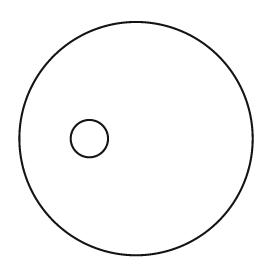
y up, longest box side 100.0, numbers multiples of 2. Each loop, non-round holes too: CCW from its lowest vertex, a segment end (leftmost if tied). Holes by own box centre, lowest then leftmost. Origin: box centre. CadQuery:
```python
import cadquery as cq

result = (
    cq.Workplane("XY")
    .moveTo(0.0, 0.0)
    .circle(50.0)
    .moveTo(-20.0, 0.0)
    .circle(8.0)
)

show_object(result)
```